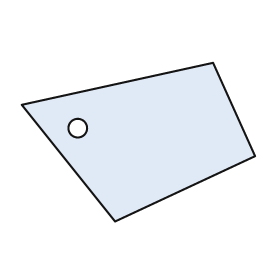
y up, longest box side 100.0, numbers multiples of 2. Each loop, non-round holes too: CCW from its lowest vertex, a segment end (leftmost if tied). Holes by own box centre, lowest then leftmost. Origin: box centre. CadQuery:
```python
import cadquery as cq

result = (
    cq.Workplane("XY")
    .moveTo(-10.0, -34.0)
    .lineTo(50.0, -6.0)
    .lineTo(32.0, 34.0)
    .lineTo(-50.0, 16.0)
    .close()
    .moveTo(-26.0, 6.0)
    .circle(4.0)
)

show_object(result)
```